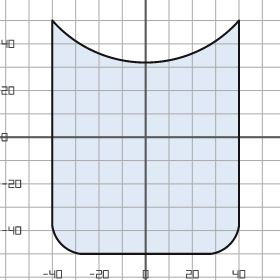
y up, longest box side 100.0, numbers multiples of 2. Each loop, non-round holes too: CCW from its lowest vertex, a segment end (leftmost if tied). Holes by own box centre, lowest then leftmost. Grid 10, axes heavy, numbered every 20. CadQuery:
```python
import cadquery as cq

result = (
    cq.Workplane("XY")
    .moveTo(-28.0, -50.0)
    .lineTo(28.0, -50.0)
    .threePointArc((36.0, -46.0), (40.0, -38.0))
    .lineTo(40.0, 50.0)
    .threePointArc((0.0, 32.0), (-40.0, 50.0))
    .lineTo(-40.0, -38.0)
    .threePointArc((-36.0, -46.0), (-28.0, -50.0))
    .close()
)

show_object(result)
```